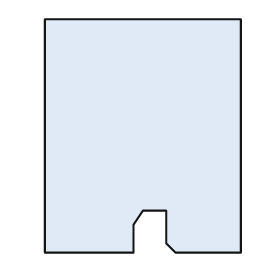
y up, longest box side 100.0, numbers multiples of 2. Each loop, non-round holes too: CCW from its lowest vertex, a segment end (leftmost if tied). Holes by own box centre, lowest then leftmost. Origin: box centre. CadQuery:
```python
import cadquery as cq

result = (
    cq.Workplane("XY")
    .moveTo(-42.0, -50.0)
    .lineTo(-4.0, -50.0)
    .lineTo(-4.0, -38.0)
    .lineTo(0.0, -32.0)
    .lineTo(10.0, -32.0)
    .lineTo(10.0, -46.0)
    .lineTo(14.0, -50.0)
    .lineTo(42.0, -50.0)
    .lineTo(42.0, 50.0)
    .lineTo(-42.0, 50.0)
    .close()
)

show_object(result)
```